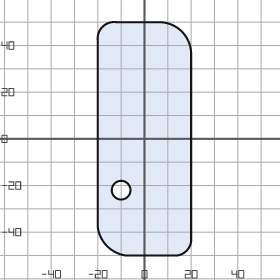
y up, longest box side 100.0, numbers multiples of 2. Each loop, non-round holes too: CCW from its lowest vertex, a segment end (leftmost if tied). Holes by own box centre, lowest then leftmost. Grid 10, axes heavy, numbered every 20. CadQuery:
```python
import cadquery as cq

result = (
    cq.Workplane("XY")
    .moveTo(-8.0, -50.0)
    .lineTo(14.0, -50.0)
    .threePointArc((18.0, -48.0), (20.0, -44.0))
    .lineTo(20.0, 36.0)
    .threePointArc((16.0, 46.0), (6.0, 50.0))
    .lineTo(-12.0, 50.0)
    .threePointArc((-18.0, 48.0), (-20.0, 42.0))
    .lineTo(-20.0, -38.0)
    .threePointArc((-16.0, -46.0), (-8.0, -50.0))
    .close()
    .moveTo(-10.0, -22.0)
    .circle(4.0)
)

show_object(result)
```